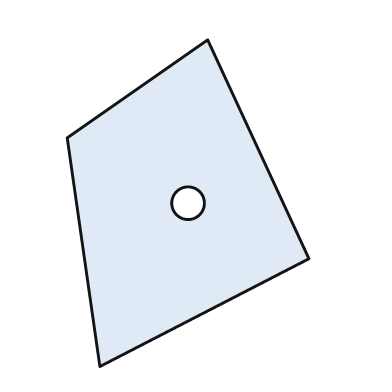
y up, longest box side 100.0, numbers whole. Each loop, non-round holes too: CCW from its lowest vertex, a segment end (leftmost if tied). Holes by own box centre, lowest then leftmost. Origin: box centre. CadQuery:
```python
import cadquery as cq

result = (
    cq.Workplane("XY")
    .moveTo(-27.0, -50.0)
    .lineTo(37.0, -17.0)
    .lineTo(6.0, 50.0)
    .lineTo(-37.0, 20.0)
    .close()
    .moveTo(0.0, 0.0)
    .circle(5.0)
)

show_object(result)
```